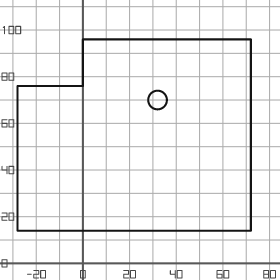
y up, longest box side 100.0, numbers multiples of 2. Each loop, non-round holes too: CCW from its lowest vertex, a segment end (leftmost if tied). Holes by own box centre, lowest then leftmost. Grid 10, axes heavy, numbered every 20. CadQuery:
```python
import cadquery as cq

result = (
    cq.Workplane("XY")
    .moveTo(-28.0, 14.0)
    .lineTo(72.0, 14.0)
    .lineTo(72.0, 96.0)
    .lineTo(0.0, 96.0)
    .lineTo(0.0, 76.0)
    .lineTo(-28.0, 76.0)
    .close()
    .moveTo(32.0, 70.0)
    .circle(4.0)
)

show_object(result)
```